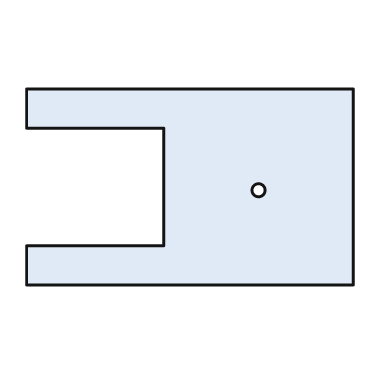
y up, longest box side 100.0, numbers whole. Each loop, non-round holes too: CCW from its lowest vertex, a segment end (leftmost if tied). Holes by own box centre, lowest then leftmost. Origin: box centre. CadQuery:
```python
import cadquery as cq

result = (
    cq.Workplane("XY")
    .moveTo(-50.0, -30.0)
    .lineTo(50.0, -30.0)
    .lineTo(50.0, 30.0)
    .lineTo(-50.0, 30.0)
    .lineTo(-50.0, 18.0)
    .lineTo(-8.0, 18.0)
    .lineTo(-8.0, -18.0)
    .lineTo(-50.0, -18.0)
    .close()
    .moveTo(21.0, -1.0)
    .circle(2.0)
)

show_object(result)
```